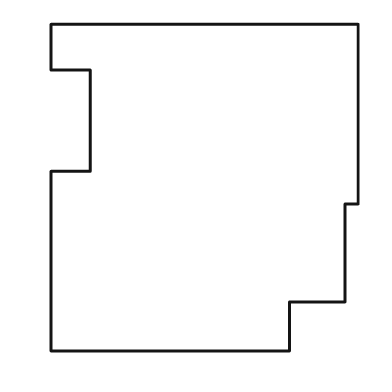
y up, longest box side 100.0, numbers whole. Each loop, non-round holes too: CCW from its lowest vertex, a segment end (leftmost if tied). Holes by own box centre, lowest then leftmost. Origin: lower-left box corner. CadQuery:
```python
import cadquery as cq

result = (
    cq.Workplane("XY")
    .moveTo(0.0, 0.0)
    .lineTo(73.0, 0.0)
    .lineTo(73.0, 15.0)
    .lineTo(90.0, 15.0)
    .lineTo(90.0, 45.0)
    .lineTo(94.0, 45.0)
    .lineTo(94.0, 100.0)
    .lineTo(0.0, 100.0)
    .lineTo(0.0, 86.0)
    .lineTo(12.0, 86.0)
    .lineTo(12.0, 55.0)
    .lineTo(0.0, 55.0)
    .close()
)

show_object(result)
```